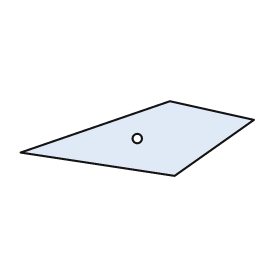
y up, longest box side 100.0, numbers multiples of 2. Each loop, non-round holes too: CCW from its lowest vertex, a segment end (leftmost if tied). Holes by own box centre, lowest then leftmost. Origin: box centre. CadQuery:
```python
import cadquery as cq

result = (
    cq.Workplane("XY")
    .moveTo(16.0, -16.0)
    .lineTo(50.0, 8.0)
    .lineTo(14.0, 16.0)
    .lineTo(-50.0, -6.0)
    .close()
    .moveTo(0.0, 0.0)
    .circle(2.0)
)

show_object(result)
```